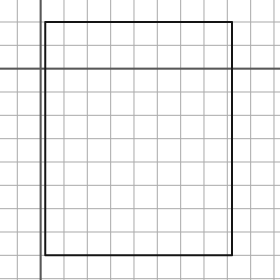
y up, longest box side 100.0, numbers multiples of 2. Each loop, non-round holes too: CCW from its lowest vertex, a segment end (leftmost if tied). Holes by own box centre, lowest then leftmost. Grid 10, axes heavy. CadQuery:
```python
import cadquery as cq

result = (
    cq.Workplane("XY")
    .moveTo(2.0, -80.0)
    .lineTo(82.0, -80.0)
    .lineTo(82.0, 20.0)
    .lineTo(2.0, 20.0)
    .close()
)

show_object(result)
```